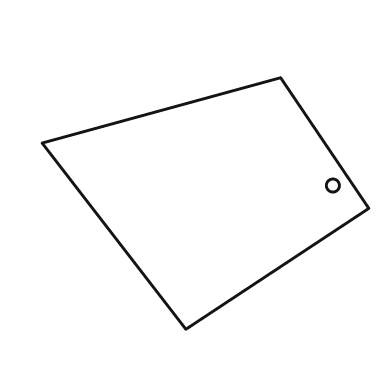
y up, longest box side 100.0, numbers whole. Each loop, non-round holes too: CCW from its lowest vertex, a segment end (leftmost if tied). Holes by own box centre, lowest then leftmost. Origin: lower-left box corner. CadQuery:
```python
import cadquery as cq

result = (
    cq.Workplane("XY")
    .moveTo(44.0, 0.0)
    .lineTo(100.0, 37.0)
    .lineTo(73.0, 77.0)
    .lineTo(0.0, 57.0)
    .close()
    .moveTo(89.0, 44.0)
    .circle(2.0)
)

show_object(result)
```